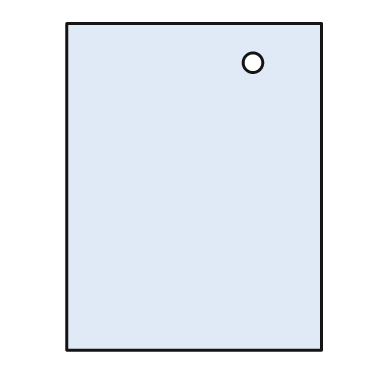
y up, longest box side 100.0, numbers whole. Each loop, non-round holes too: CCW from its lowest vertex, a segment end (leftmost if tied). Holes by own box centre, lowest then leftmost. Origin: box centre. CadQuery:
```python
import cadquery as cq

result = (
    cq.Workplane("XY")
    .moveTo(-39.0, -50.0)
    .lineTo(39.0, -50.0)
    .lineTo(39.0, 50.0)
    .lineTo(-39.0, 50.0)
    .close()
    .moveTo(18.0, 38.0)
    .circle(3.0)
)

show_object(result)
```